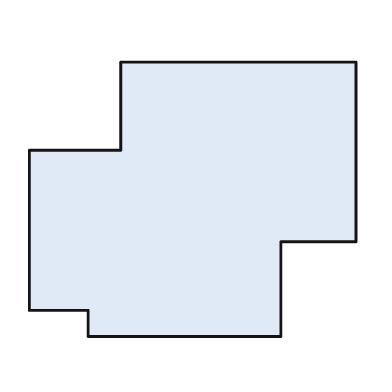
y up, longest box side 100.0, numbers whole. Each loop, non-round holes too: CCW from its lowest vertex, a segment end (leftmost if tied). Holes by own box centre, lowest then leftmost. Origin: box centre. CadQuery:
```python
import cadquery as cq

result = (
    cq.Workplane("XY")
    .moveTo(-32.0, -42.0)
    .lineTo(27.0, -42.0)
    .lineTo(27.0, -13.0)
    .lineTo(50.0, -13.0)
    .lineTo(50.0, 42.0)
    .lineTo(-22.0, 42.0)
    .lineTo(-22.0, 15.0)
    .lineTo(-50.0, 15.0)
    .lineTo(-50.0, -34.0)
    .lineTo(-32.0, -34.0)
    .close()
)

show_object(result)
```